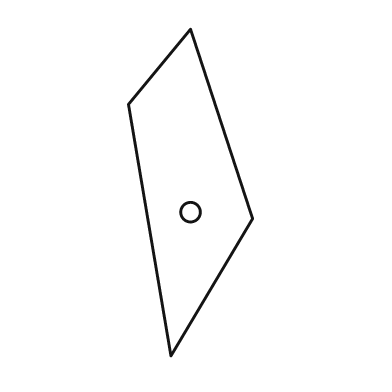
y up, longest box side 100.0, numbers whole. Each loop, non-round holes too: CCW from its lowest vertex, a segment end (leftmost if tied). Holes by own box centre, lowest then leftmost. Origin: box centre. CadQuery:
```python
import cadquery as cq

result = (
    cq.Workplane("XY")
    .moveTo(-6.0, -50.0)
    .lineTo(19.0, -8.0)
    .lineTo(0.0, 50.0)
    .lineTo(-19.0, 27.0)
    .close()
    .moveTo(0.0, -6.0)
    .circle(3.0)
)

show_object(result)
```